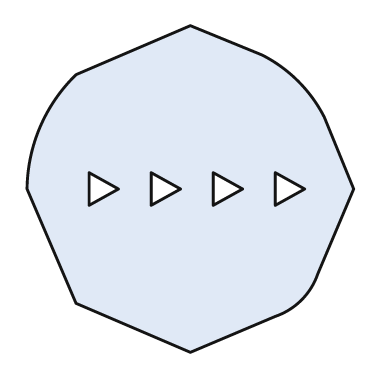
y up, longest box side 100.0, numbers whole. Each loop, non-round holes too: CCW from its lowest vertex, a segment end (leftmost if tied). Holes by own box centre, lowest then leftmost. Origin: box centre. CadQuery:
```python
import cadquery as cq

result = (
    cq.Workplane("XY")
    .moveTo(0.0, -50.0)
    .lineTo(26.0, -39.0)
    .threePointArc((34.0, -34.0), (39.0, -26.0))
    .lineTo(50.0, 0.0)
    .lineTo(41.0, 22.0)
    .threePointArc((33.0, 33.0), (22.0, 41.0))
    .lineTo(0.0, 50.0)
    .lineTo(-35.0, 35.0)
    .threePointArc((-46.0, 19.0), (-50.0, 0.0))
    .lineTo(-35.0, -35.0)
    .close()
    .moveTo(-31.0, -5.0)
    .lineTo(-22.0, 0.0)
    .lineTo(-31.0, 5.0)
    .close()
    .moveTo(-12.0, -5.0)
    .lineTo(-3.0, 0.0)
    .lineTo(-12.0, 5.0)
    .close()
    .moveTo(7.0, -5.0)
    .lineTo(16.0, 0.0)
    .lineTo(7.0, 5.0)
    .close()
    .moveTo(26.0, -5.0)
    .lineTo(35.0, 0.0)
    .lineTo(26.0, 5.0)
    .close()
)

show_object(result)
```